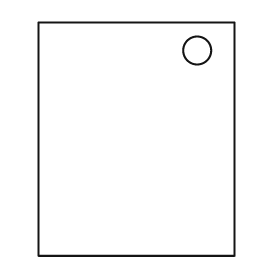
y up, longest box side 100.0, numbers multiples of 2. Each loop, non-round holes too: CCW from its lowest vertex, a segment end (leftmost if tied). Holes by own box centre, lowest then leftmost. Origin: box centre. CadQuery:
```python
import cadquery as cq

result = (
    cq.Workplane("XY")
    .moveTo(-42.0, -50.0)
    .lineTo(42.0, -50.0)
    .lineTo(42.0, 50.0)
    .lineTo(-42.0, 50.0)
    .close()
    .moveTo(26.0, 38.0)
    .circle(6.0)
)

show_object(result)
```